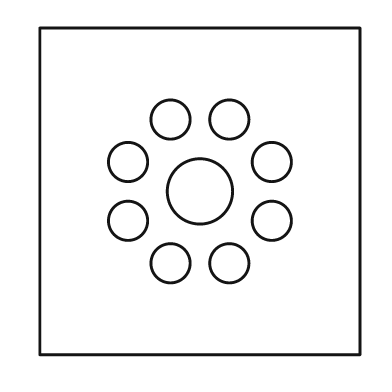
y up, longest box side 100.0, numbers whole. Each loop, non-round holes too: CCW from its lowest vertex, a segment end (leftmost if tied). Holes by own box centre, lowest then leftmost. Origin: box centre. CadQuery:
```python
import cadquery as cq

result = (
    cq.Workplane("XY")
    .moveTo(-49.0, -50.0)
    .lineTo(49.0, -50.0)
    .lineTo(49.0, 50.0)
    .lineTo(-49.0, 50.0)
    .close()
    .moveTo(-9.0, -22.0)
    .circle(6.0)
    .moveTo(9.0, -22.0)
    .circle(6.0)
    .moveTo(-22.0, -9.0)
    .circle(6.0)
    .moveTo(22.0, -9.0)
    .circle(6.0)
    .moveTo(0.0, 0.0)
    .circle(10.0)
    .moveTo(-22.0, 9.0)
    .circle(6.0)
    .moveTo(22.0, 9.0)
    .circle(6.0)
    .moveTo(-9.0, 22.0)
    .circle(6.0)
    .moveTo(9.0, 22.0)
    .circle(6.0)
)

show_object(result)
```